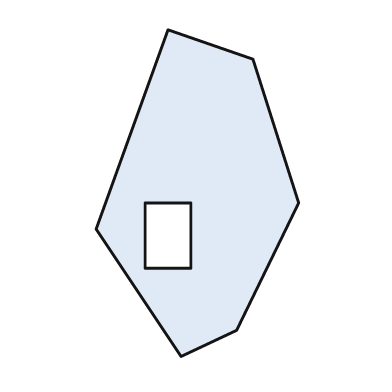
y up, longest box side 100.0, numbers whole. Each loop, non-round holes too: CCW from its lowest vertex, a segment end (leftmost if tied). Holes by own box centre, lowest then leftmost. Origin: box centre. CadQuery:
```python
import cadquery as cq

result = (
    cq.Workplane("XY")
    .moveTo(-5.0, -50.0)
    .lineTo(12.0, -42.0)
    .lineTo(31.0, -3.0)
    .lineTo(17.0, 41.0)
    .lineTo(-9.0, 50.0)
    .lineTo(-31.0, -11.0)
    .close()
    .moveTo(-16.0, -23.0)
    .lineTo(-2.0, -23.0)
    .lineTo(-2.0, -3.0)
    .lineTo(-16.0, -3.0)
    .close()
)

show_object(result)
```